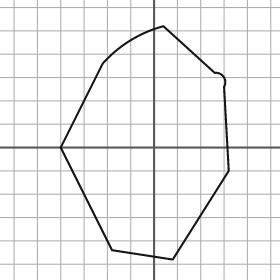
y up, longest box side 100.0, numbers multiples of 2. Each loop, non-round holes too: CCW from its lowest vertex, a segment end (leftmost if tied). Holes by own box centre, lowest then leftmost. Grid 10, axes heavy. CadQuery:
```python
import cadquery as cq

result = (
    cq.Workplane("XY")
    .moveTo(8.0, -48.0)
    .lineTo(32.0, -10.0)
    .lineTo(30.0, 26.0)
    .threePointArc((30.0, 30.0), (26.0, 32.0))
    .lineTo(4.0, 52.0)
    .threePointArc((-10.0, 46.0), (-22.0, 36.0))
    .lineTo(-40.0, 0.0)
    .lineTo(-18.0, -44.0)
    .close()
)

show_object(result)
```